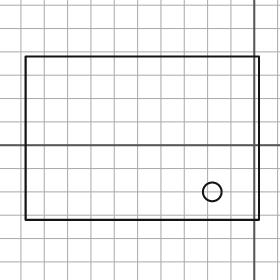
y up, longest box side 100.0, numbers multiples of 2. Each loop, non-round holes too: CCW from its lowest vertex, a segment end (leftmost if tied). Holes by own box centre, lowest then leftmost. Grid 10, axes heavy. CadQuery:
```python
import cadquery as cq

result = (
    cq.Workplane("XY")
    .moveTo(-98.0, -32.0)
    .lineTo(2.0, -32.0)
    .lineTo(2.0, 38.0)
    .lineTo(-98.0, 38.0)
    .close()
    .moveTo(-18.0, -20.0)
    .circle(4.0)
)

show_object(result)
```